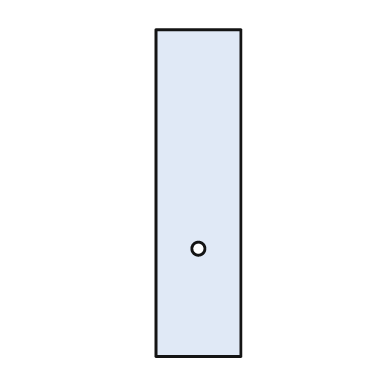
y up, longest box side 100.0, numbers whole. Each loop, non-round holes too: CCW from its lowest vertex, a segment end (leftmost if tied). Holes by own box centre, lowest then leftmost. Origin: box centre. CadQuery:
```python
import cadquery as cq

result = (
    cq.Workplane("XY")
    .moveTo(-13.0, -50.0)
    .lineTo(13.0, -50.0)
    .lineTo(13.0, 50.0)
    .lineTo(-13.0, 50.0)
    .close()
    .moveTo(0.0, -17.0)
    .circle(2.0)
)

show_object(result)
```